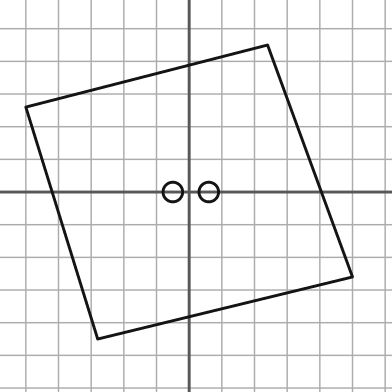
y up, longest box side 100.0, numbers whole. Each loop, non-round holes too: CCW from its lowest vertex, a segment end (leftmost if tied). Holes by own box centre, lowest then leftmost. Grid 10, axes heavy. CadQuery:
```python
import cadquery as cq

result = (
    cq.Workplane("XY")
    .moveTo(-28.0, -45.0)
    .lineTo(50.0, -26.0)
    .lineTo(24.0, 45.0)
    .lineTo(-50.0, 26.0)
    .close()
    .moveTo(-5.0, 0.0)
    .circle(3.0)
    .moveTo(6.0, 0.0)
    .circle(3.0)
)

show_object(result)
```